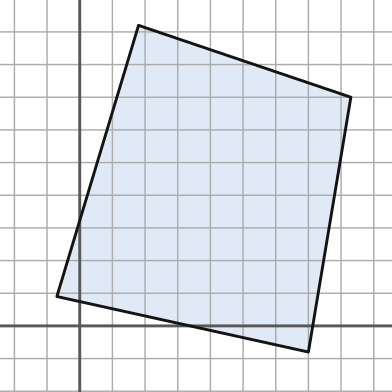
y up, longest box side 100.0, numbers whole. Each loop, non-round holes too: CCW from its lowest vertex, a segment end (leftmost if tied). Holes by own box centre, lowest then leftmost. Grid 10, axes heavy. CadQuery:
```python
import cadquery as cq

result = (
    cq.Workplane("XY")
    .moveTo(70.0, -8.0)
    .lineTo(83.0, 70.0)
    .lineTo(18.0, 92.0)
    .lineTo(-7.0, 9.0)
    .close()
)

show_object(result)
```